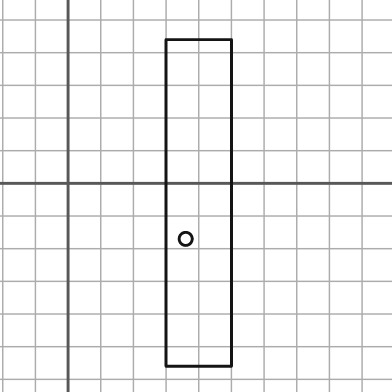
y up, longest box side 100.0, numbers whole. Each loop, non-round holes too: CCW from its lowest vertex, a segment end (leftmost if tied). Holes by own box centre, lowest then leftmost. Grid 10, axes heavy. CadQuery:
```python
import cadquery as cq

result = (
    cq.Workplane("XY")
    .moveTo(30.0, -56.0)
    .lineTo(50.0, -56.0)
    .lineTo(50.0, 44.0)
    .lineTo(30.0, 44.0)
    .close()
    .moveTo(36.0, -17.0)
    .circle(2.0)
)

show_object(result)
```